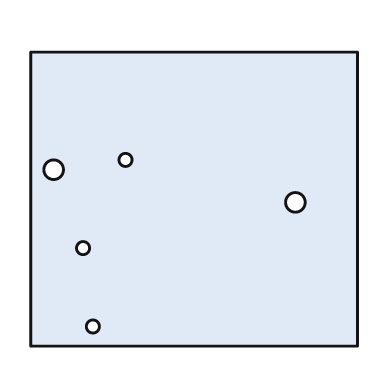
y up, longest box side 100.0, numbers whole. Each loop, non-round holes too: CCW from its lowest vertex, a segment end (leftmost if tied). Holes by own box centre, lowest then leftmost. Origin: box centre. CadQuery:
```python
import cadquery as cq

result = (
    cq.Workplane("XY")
    .moveTo(-50.0, -45.0)
    .lineTo(50.0, -45.0)
    .lineTo(50.0, 45.0)
    .lineTo(-50.0, 45.0)
    .close()
    .moveTo(-31.0, -39.0)
    .circle(2.0)
    .moveTo(-34.0, -15.0)
    .circle(2.0)
    .moveTo(31.0, -1.0)
    .circle(3.0)
    .moveTo(-43.0, 9.0)
    .circle(3.0)
    .moveTo(-21.0, 12.0)
    .circle(2.0)
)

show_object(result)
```